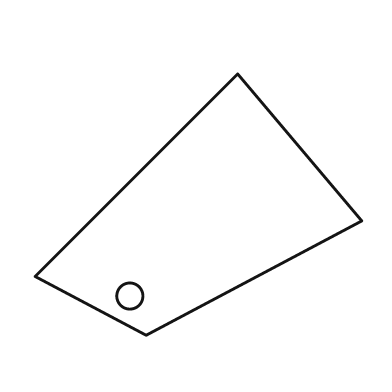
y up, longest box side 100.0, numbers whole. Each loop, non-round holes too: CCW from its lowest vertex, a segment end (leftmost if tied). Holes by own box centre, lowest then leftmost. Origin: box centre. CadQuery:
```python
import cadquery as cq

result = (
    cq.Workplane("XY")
    .moveTo(-16.0, -40.0)
    .lineTo(50.0, -5.0)
    .lineTo(12.0, 40.0)
    .lineTo(-50.0, -22.0)
    .close()
    .moveTo(-21.0, -28.0)
    .circle(4.0)
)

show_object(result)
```